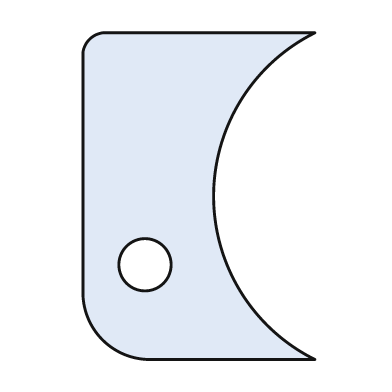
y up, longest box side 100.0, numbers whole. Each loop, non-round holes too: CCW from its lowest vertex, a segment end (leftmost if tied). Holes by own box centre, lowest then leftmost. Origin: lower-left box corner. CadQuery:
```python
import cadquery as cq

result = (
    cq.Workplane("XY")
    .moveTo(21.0, 0.0)
    .lineTo(71.0, 0.0)
    .threePointArc((40.0, 50.0), (71.0, 100.0))
    .lineTo(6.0, 100.0)
    .threePointArc((2.0, 98.0), (0.0, 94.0))
    .lineTo(0.0, 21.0)
    .threePointArc((6.0, 6.0), (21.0, 0.0))
    .close()
    .moveTo(19.0, 29.0)
    .circle(8.0)
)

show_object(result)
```